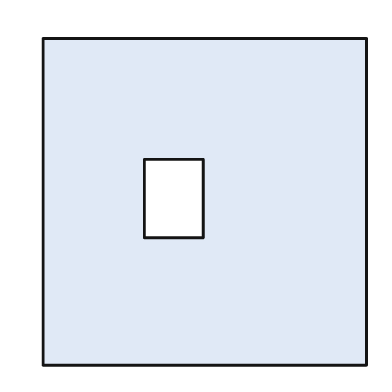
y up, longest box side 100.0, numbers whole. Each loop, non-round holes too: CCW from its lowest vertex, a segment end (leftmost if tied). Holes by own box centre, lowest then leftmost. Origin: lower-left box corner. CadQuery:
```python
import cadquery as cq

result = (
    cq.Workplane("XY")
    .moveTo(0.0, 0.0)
    .lineTo(99.0, 0.0)
    .lineTo(99.0, 100.0)
    .lineTo(0.0, 100.0)
    .close()
    .moveTo(31.0, 39.0)
    .lineTo(49.0, 39.0)
    .lineTo(49.0, 63.0)
    .lineTo(31.0, 63.0)
    .close()
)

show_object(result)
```